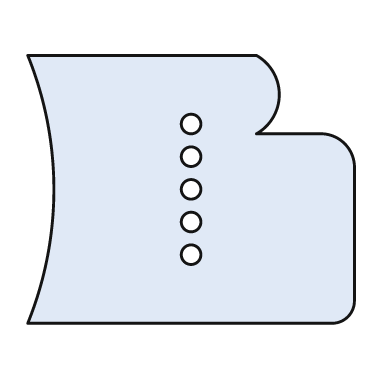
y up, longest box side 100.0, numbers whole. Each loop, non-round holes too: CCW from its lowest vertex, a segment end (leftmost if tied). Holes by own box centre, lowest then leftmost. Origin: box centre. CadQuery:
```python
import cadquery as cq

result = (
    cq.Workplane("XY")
    .moveTo(-50.0, -41.0)
    .lineTo(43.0, -41.0)
    .threePointArc((48.0, -39.0), (50.0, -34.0))
    .lineTo(50.0, 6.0)
    .threePointArc((47.0, 14.0), (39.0, 17.0))
    .lineTo(20.0, 17.0)
    .threePointArc((27.0, 29.0), (20.0, 41.0))
    .lineTo(-50.0, 41.0)
    .threePointArc((-42.0, 0.0), (-50.0, -41.0))
    .close()
    .moveTo(0.0, -20.0)
    .circle(3.0)
    .moveTo(0.0, -10.0)
    .circle(3.0)
    .moveTo(0.0, 0.0)
    .circle(3.0)
    .moveTo(0.0, 10.0)
    .circle(3.0)
    .moveTo(0.0, 20.0)
    .circle(3.0)
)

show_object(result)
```